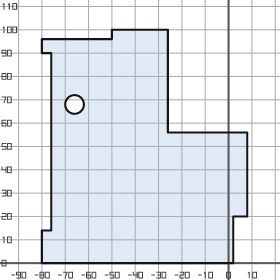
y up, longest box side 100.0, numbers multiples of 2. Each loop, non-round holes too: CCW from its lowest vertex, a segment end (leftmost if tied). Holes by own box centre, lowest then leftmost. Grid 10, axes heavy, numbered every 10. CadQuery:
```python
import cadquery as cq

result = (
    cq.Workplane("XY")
    .moveTo(-80.0, 0.0)
    .lineTo(2.0, 0.0)
    .lineTo(2.0, 20.0)
    .lineTo(8.0, 20.0)
    .lineTo(8.0, 56.0)
    .lineTo(-26.0, 56.0)
    .lineTo(-26.0, 100.0)
    .lineTo(-50.0, 100.0)
    .lineTo(-50.0, 96.0)
    .lineTo(-80.0, 96.0)
    .lineTo(-80.0, 90.0)
    .lineTo(-76.0, 90.0)
    .lineTo(-76.0, 14.0)
    .lineTo(-80.0, 14.0)
    .close()
    .moveTo(-66.0, 68.0)
    .circle(4.0)
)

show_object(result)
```